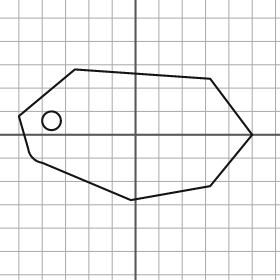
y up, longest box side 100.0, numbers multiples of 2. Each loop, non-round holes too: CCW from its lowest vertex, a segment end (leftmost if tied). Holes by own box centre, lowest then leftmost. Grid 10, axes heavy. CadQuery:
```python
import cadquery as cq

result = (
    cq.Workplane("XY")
    .moveTo(-2.0, -28.0)
    .lineTo(32.0, -22.0)
    .lineTo(50.0, 0.0)
    .lineTo(32.0, 24.0)
    .lineTo(-26.0, 28.0)
    .lineTo(-50.0, 8.0)
    .lineTo(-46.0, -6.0)
    .threePointArc((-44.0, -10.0), (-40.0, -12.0))
    .close()
    .moveTo(-36.0, 6.0)
    .circle(4.0)
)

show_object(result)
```